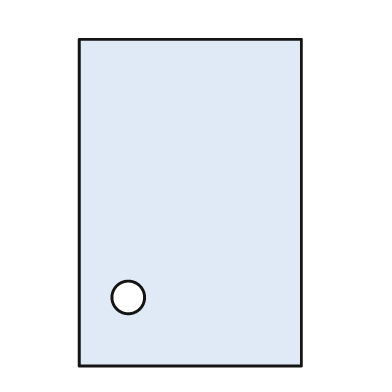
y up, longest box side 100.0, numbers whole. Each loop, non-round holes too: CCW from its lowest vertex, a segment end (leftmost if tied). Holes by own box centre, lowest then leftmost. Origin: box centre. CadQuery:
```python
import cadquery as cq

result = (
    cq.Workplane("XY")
    .moveTo(-34.0, -50.0)
    .lineTo(34.0, -50.0)
    .lineTo(34.0, 50.0)
    .lineTo(-34.0, 50.0)
    .close()
    .moveTo(-19.0, -29.0)
    .circle(5.0)
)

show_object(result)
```